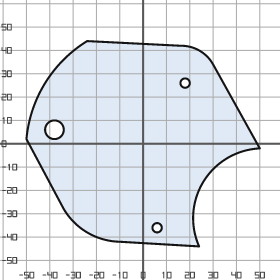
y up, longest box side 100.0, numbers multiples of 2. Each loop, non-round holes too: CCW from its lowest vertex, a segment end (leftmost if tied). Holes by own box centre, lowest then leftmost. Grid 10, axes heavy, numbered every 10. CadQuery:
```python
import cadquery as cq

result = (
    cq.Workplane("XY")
    .moveTo(24.0, -44.0)
    .threePointArc((26.0, -16.0), (50.0, -2.0))
    .lineTo(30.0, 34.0)
    .threePointArc((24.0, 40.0), (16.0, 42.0))
    .lineTo(-24.0, 44.0)
    .threePointArc((-42.0, 26.0), (-50.0, 2.0))
    .lineTo(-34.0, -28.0)
    .threePointArc((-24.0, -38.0), (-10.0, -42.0))
    .close()
    .moveTo(6.0, -36.0)
    .circle(2.0)
    .moveTo(-38.0, 6.0)
    .circle(4.0)
    .moveTo(18.0, 26.0)
    .circle(2.0)
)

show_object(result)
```